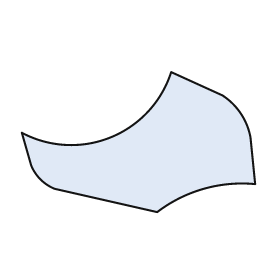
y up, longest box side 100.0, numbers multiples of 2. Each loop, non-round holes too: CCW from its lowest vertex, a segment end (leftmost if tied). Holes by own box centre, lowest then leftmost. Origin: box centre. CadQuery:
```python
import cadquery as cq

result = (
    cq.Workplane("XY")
    .moveTo(8.0, -30.0)
    .threePointArc((28.0, -20.0), (50.0, -18.0))
    .lineTo(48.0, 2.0)
    .threePointArc((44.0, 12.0), (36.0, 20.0))
    .lineTo(14.0, 30.0)
    .threePointArc((-12.0, 2.0), (-50.0, 4.0))
    .lineTo(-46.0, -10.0)
    .threePointArc((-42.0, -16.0), (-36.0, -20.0))
    .close()
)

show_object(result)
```